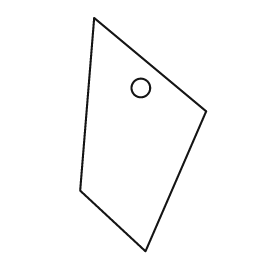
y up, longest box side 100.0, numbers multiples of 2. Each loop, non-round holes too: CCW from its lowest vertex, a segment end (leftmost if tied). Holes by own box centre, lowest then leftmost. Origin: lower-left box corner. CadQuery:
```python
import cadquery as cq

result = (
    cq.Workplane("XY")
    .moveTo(28.0, 0.0)
    .lineTo(54.0, 60.0)
    .lineTo(6.0, 100.0)
    .lineTo(0.0, 26.0)
    .close()
    .moveTo(26.0, 70.0)
    .circle(4.0)
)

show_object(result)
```